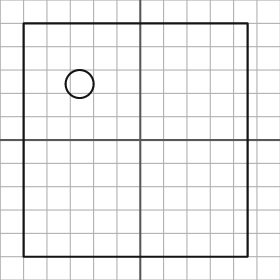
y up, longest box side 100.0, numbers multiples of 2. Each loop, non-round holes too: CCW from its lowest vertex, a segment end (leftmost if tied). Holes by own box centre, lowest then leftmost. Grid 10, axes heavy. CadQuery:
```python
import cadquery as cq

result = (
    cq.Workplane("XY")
    .moveTo(-50.0, -50.0)
    .lineTo(46.0, -50.0)
    .lineTo(46.0, 50.0)
    .lineTo(-50.0, 50.0)
    .close()
    .moveTo(-26.0, 24.0)
    .circle(6.0)
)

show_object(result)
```